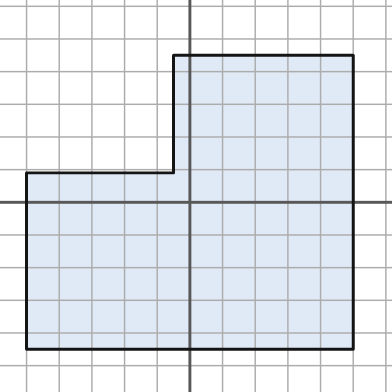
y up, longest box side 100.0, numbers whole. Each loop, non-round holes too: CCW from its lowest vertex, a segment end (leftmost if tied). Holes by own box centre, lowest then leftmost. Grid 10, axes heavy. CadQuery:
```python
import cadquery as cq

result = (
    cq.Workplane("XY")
    .moveTo(-50.0, -45.0)
    .lineTo(50.0, -45.0)
    .lineTo(50.0, 45.0)
    .lineTo(-5.0, 45.0)
    .lineTo(-5.0, 9.0)
    .lineTo(-50.0, 9.0)
    .close()
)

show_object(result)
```